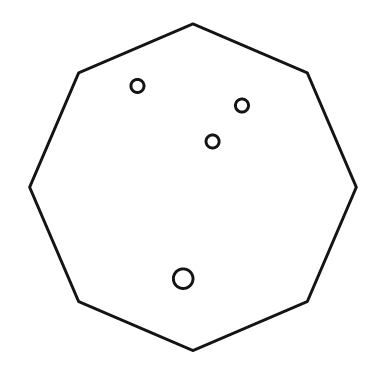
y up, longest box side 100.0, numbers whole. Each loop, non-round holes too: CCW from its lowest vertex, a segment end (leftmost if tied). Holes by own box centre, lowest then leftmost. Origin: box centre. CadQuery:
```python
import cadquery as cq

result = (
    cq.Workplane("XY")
    .moveTo(0.0, -50.0)
    .lineTo(35.0, -35.0)
    .lineTo(50.0, 0.0)
    .lineTo(35.0, 35.0)
    .lineTo(0.0, 50.0)
    .lineTo(-35.0, 35.0)
    .lineTo(-50.0, 0.0)
    .lineTo(-35.0, -35.0)
    .close()
    .moveTo(-3.0, -28.0)
    .circle(3.0)
    .moveTo(6.0, 14.0)
    .circle(2.0)
    .moveTo(15.0, 25.0)
    .circle(2.0)
    .moveTo(-17.0, 31.0)
    .circle(2.0)
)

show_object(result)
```